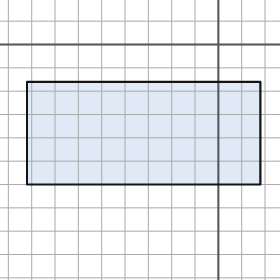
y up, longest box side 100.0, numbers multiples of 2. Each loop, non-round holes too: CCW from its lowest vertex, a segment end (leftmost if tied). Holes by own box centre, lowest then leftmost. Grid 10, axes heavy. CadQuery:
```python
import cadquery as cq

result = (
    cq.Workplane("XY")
    .moveTo(-82.0, -60.0)
    .lineTo(18.0, -60.0)
    .lineTo(18.0, -16.0)
    .lineTo(-82.0, -16.0)
    .close()
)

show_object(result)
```